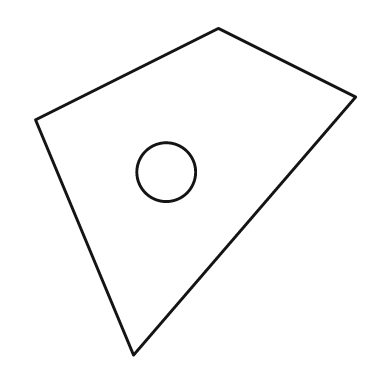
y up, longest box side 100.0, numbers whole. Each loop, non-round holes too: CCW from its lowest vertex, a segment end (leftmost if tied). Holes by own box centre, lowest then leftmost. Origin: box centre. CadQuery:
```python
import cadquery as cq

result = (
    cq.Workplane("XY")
    .moveTo(-19.0, -50.0)
    .lineTo(49.0, 29.0)
    .lineTo(7.0, 50.0)
    .lineTo(-49.0, 22.0)
    .close()
    .moveTo(-9.0, 6.0)
    .circle(9.0)
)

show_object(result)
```